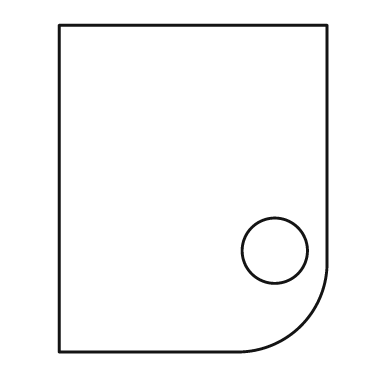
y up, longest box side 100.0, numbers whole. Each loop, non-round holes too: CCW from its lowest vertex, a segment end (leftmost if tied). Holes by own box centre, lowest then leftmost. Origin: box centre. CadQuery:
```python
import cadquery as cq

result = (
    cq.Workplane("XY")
    .moveTo(-41.0, -50.0)
    .lineTo(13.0, -50.0)
    .threePointArc((33.0, -42.0), (41.0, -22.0))
    .lineTo(41.0, 50.0)
    .lineTo(-41.0, 50.0)
    .close()
    .moveTo(25.0, -19.0)
    .circle(10.0)
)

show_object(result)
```